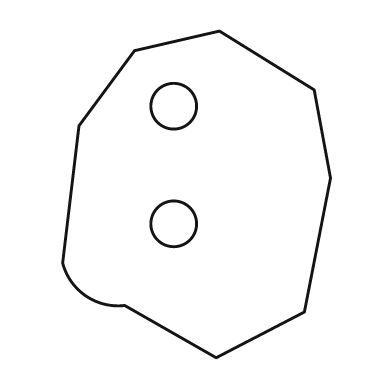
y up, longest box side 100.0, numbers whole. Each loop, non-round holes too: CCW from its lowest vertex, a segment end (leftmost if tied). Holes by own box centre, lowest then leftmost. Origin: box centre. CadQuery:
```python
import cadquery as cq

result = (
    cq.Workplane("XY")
    .moveTo(6.0, -50.0)
    .lineTo(33.0, -36.0)
    .lineTo(41.0, 5.0)
    .lineTo(36.0, 32.0)
    .lineTo(7.0, 50.0)
    .lineTo(-19.0, 44.0)
    .lineTo(-36.0, 21.0)
    .lineTo(-41.0, -21.0)
    .threePointArc((-34.0, -31.0), (-22.0, -34.0))
    .close()
    .moveTo(-7.0, -9.0)
    .circle(7.0)
    .moveTo(-7.0, 27.0)
    .circle(7.0)
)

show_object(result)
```